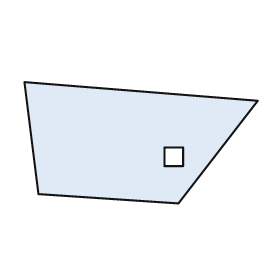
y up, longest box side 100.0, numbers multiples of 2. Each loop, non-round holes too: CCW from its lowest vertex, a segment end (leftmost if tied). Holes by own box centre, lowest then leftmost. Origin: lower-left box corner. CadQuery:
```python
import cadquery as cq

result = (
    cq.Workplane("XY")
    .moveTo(66.0, 0.0)
    .lineTo(100.0, 44.0)
    .lineTo(0.0, 52.0)
    .lineTo(6.0, 4.0)
    .close()
    .moveTo(60.0, 16.0)
    .lineTo(68.0, 16.0)
    .lineTo(68.0, 24.0)
    .lineTo(60.0, 24.0)
    .close()
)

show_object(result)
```